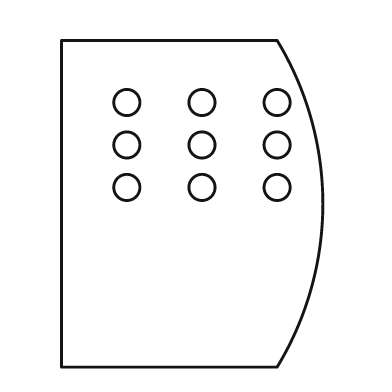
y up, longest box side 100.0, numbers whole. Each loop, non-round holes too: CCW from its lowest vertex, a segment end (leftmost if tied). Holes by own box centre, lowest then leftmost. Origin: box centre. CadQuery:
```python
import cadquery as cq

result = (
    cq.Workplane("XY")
    .moveTo(-40.0, -50.0)
    .lineTo(26.0, -50.0)
    .threePointArc((40.0, 0.0), (26.0, 50.0))
    .lineTo(-40.0, 50.0)
    .close()
    .moveTo(-20.0, 5.0)
    .circle(4.0)
    .moveTo(3.0, 5.0)
    .circle(4.0)
    .moveTo(26.0, 5.0)
    .circle(4.0)
    .moveTo(-20.0, 18.0)
    .circle(4.0)
    .moveTo(3.0, 18.0)
    .circle(4.0)
    .moveTo(26.0, 18.0)
    .circle(4.0)
    .moveTo(-20.0, 31.0)
    .circle(4.0)
    .moveTo(3.0, 31.0)
    .circle(4.0)
    .moveTo(26.0, 31.0)
    .circle(4.0)
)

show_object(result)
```